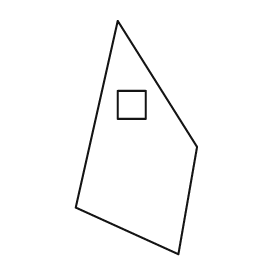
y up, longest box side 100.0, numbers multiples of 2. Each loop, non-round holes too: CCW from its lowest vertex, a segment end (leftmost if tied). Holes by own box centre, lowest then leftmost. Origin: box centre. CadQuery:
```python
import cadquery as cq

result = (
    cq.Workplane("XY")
    .moveTo(18.0, -50.0)
    .lineTo(26.0, -4.0)
    .lineTo(-8.0, 50.0)
    .lineTo(-26.0, -30.0)
    .close()
    .moveTo(-8.0, 8.0)
    .lineTo(4.0, 8.0)
    .lineTo(4.0, 20.0)
    .lineTo(-8.0, 20.0)
    .close()
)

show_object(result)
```